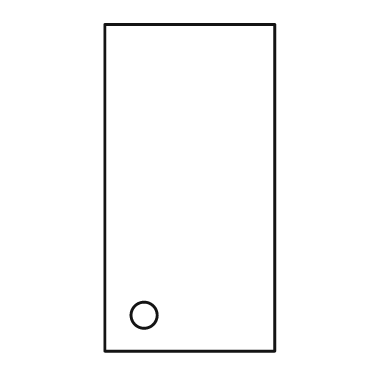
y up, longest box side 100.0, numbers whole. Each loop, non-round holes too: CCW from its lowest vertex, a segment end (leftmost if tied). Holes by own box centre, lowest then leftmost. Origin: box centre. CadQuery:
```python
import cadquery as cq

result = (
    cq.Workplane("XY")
    .moveTo(-26.0, -50.0)
    .lineTo(26.0, -50.0)
    .lineTo(26.0, 50.0)
    .lineTo(-26.0, 50.0)
    .close()
    .moveTo(-14.0, -39.0)
    .circle(4.0)
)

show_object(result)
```